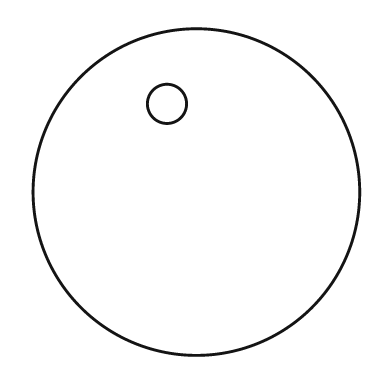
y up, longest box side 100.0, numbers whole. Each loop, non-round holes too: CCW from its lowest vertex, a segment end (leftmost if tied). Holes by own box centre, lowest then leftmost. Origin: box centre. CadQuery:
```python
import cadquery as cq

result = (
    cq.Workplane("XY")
    .moveTo(0.0, 0.0)
    .circle(50.0)
    .moveTo(-9.0, 27.0)
    .circle(6.0)
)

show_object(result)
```